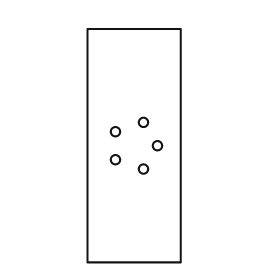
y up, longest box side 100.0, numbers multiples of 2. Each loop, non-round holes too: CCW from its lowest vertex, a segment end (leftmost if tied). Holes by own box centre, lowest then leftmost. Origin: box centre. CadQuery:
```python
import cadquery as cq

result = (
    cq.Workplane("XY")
    .moveTo(-20.0, -50.0)
    .lineTo(20.0, -50.0)
    .lineTo(20.0, 50.0)
    .lineTo(-20.0, 50.0)
    .close()
    .moveTo(4.0, -10.0)
    .circle(2.0)
    .moveTo(-8.0, -6.0)
    .circle(2.0)
    .moveTo(10.0, 0.0)
    .circle(2.0)
    .moveTo(-8.0, 6.0)
    .circle(2.0)
    .moveTo(4.0, 10.0)
    .circle(2.0)
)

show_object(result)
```